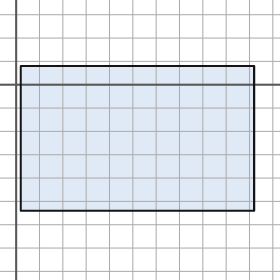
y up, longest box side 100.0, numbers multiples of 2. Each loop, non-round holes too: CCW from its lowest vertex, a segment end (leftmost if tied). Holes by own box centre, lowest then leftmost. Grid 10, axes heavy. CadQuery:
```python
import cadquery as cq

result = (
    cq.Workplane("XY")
    .moveTo(2.0, -54.0)
    .lineTo(102.0, -54.0)
    .lineTo(102.0, 8.0)
    .lineTo(2.0, 8.0)
    .close()
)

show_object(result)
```